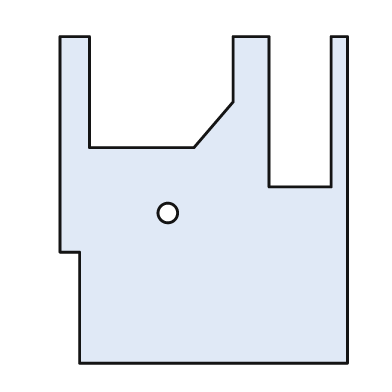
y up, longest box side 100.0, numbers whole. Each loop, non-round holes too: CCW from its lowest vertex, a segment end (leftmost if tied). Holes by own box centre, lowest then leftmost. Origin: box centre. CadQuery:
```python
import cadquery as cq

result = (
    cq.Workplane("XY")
    .moveTo(-38.0, -50.0)
    .lineTo(44.0, -50.0)
    .lineTo(44.0, 50.0)
    .lineTo(39.0, 50.0)
    .lineTo(39.0, 4.0)
    .lineTo(20.0, 4.0)
    .lineTo(20.0, 50.0)
    .lineTo(9.0, 50.0)
    .lineTo(9.0, 30.0)
    .lineTo(-3.0, 16.0)
    .lineTo(-35.0, 16.0)
    .lineTo(-35.0, 50.0)
    .lineTo(-44.0, 50.0)
    .lineTo(-44.0, -16.0)
    .lineTo(-38.0, -16.0)
    .close()
    .moveTo(-11.0, -4.0)
    .circle(3.0)
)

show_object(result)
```